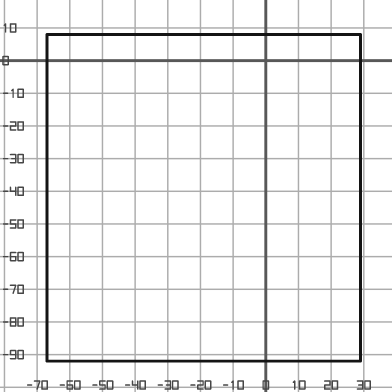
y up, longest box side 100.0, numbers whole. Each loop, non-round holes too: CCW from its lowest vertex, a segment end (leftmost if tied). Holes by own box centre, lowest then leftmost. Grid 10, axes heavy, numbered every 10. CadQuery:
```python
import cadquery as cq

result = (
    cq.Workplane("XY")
    .moveTo(-67.0, -92.0)
    .lineTo(29.0, -92.0)
    .lineTo(29.0, 8.0)
    .lineTo(-67.0, 8.0)
    .close()
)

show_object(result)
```